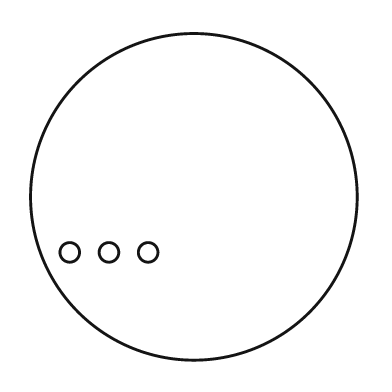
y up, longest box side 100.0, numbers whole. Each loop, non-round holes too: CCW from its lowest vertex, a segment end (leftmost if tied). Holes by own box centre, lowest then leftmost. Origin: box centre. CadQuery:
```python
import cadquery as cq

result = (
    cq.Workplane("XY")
    .moveTo(0.0, 0.0)
    .circle(50.0)
    .moveTo(-38.0, -17.0)
    .circle(3.0)
    .moveTo(-26.0, -17.0)
    .circle(3.0)
    .moveTo(-14.0, -17.0)
    .circle(3.0)
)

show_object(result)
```